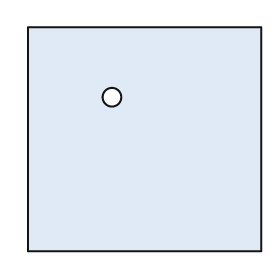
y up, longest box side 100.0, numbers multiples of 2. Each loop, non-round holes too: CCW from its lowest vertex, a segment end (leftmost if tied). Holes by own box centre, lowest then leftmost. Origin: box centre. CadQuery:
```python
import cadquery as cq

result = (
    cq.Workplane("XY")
    .moveTo(-50.0, -48.0)
    .lineTo(50.0, -48.0)
    .lineTo(50.0, 48.0)
    .lineTo(-50.0, 48.0)
    .close()
    .moveTo(-14.0, 18.0)
    .circle(4.0)
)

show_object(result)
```